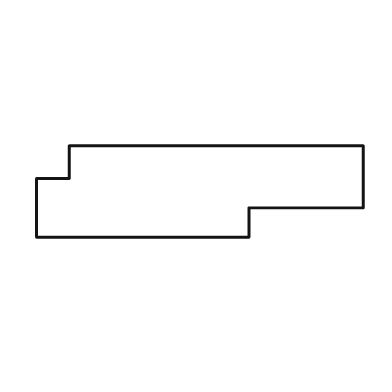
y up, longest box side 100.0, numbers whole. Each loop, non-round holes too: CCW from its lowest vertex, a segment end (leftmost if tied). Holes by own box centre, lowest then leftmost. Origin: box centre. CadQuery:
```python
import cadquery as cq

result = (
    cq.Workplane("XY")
    .moveTo(-50.0, -14.0)
    .lineTo(15.0, -14.0)
    .lineTo(15.0, -5.0)
    .lineTo(50.0, -5.0)
    .lineTo(50.0, 14.0)
    .lineTo(-40.0, 14.0)
    .lineTo(-40.0, 4.0)
    .lineTo(-50.0, 4.0)
    .close()
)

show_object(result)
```